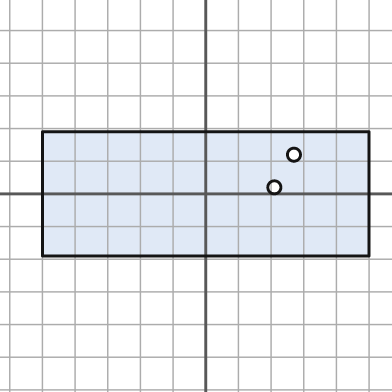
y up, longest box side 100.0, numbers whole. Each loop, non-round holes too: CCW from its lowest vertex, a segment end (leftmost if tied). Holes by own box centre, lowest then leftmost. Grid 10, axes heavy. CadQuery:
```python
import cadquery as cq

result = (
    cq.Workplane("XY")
    .moveTo(-50.0, -19.0)
    .lineTo(50.0, -19.0)
    .lineTo(50.0, 19.0)
    .lineTo(-50.0, 19.0)
    .close()
    .moveTo(21.0, 2.0)
    .circle(2.0)
    .moveTo(27.0, 12.0)
    .circle(2.0)
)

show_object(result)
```